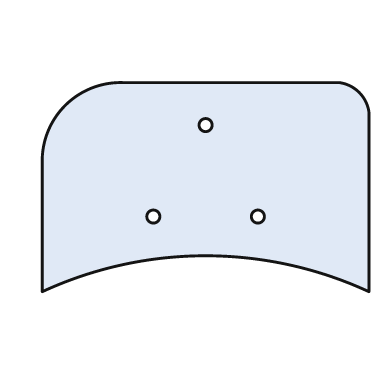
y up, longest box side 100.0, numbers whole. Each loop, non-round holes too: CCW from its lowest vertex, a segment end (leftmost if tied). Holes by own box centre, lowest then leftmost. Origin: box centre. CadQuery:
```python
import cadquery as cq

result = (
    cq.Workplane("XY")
    .moveTo(-50.0, -32.0)
    .threePointArc((0.0, -21.0), (50.0, -32.0))
    .lineTo(50.0, 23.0)
    .threePointArc((47.0, 29.0), (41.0, 32.0))
    .lineTo(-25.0, 32.0)
    .threePointArc((-43.0, 25.0), (-50.0, 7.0))
    .close()
    .moveTo(-16.0, -9.0)
    .circle(2.0)
    .moveTo(16.0, -9.0)
    .circle(2.0)
    .moveTo(0.0, 19.0)
    .circle(2.0)
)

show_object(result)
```